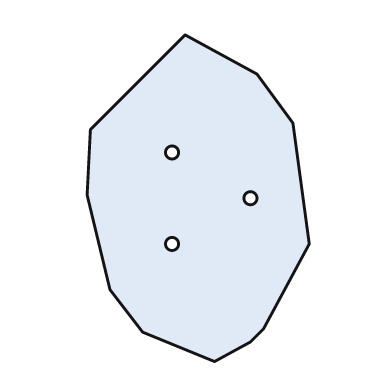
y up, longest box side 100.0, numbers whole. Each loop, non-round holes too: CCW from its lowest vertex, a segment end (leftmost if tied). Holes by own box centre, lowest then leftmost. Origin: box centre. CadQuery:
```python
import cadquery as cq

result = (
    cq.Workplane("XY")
    .moveTo(5.0, -50.0)
    .lineTo(16.0, -44.0)
    .lineTo(20.0, -40.0)
    .lineTo(34.0, -14.0)
    .lineTo(29.0, 23.0)
    .lineTo(18.0, 38.0)
    .lineTo(-4.0, 50.0)
    .lineTo(-33.0, 21.0)
    .lineTo(-34.0, 1.0)
    .lineTo(-27.0, -28.0)
    .lineTo(-17.0, -41.0)
    .close()
    .moveTo(-8.0, -14.0)
    .circle(2.0)
    .moveTo(16.0, 0.0)
    .circle(2.0)
    .moveTo(-8.0, 14.0)
    .circle(2.0)
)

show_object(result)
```